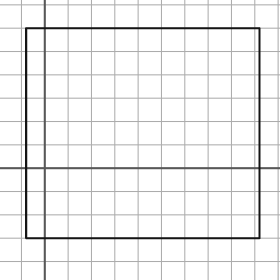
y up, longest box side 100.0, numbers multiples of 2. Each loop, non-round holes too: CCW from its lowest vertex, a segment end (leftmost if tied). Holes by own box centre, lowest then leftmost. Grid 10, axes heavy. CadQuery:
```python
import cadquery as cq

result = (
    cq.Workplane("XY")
    .moveTo(-8.0, -30.0)
    .lineTo(92.0, -30.0)
    .lineTo(92.0, 60.0)
    .lineTo(-8.0, 60.0)
    .close()
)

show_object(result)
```